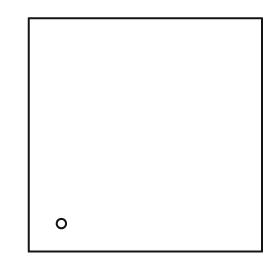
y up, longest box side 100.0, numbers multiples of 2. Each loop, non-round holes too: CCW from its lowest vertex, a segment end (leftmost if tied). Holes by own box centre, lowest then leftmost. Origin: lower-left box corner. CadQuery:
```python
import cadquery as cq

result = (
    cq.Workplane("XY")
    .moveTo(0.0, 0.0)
    .lineTo(100.0, 0.0)
    .lineTo(100.0, 100.0)
    .lineTo(0.0, 100.0)
    .close()
    .moveTo(14.0, 12.0)
    .circle(2.0)
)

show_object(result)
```